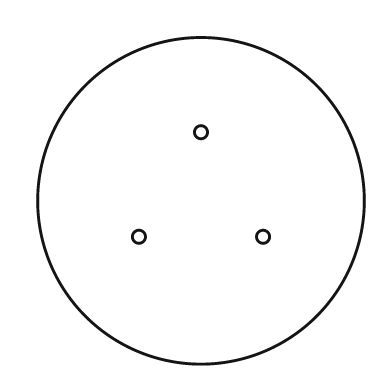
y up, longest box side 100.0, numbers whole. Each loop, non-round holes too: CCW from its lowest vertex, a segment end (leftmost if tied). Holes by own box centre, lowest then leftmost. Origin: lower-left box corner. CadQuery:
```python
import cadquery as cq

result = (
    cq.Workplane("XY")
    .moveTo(50.0, 50.0)
    .circle(50.0)
    .moveTo(31.0, 39.0)
    .circle(2.0)
    .moveTo(69.0, 39.0)
    .circle(2.0)
    .moveTo(50.0, 71.0)
    .circle(2.0)
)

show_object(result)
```